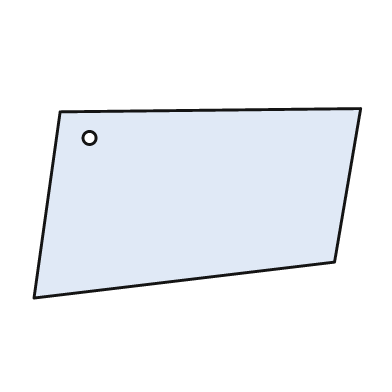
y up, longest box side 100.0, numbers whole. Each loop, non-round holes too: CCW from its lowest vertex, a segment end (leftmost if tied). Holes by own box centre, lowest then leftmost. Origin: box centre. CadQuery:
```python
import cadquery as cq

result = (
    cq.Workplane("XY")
    .moveTo(-50.0, -29.0)
    .lineTo(42.0, -18.0)
    .lineTo(50.0, 29.0)
    .lineTo(-42.0, 28.0)
    .close()
    .moveTo(-33.0, 20.0)
    .circle(2.0)
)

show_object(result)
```